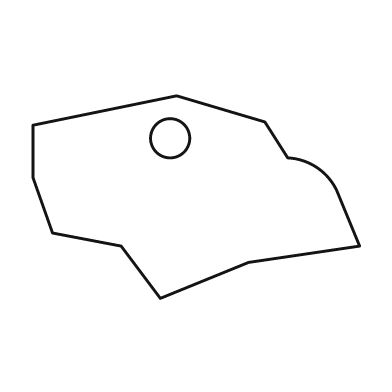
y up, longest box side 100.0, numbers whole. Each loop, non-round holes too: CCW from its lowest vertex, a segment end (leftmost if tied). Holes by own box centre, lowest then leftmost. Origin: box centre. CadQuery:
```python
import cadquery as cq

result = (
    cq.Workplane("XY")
    .moveTo(-11.0, -31.0)
    .lineTo(16.0, -20.0)
    .lineTo(50.0, -15.0)
    .lineTo(43.0, 2.0)
    .threePointArc((37.0, 9.0), (28.0, 12.0))
    .lineTo(21.0, 23.0)
    .lineTo(-6.0, 31.0)
    .lineTo(-50.0, 22.0)
    .lineTo(-50.0, 6.0)
    .lineTo(-44.0, -11.0)
    .lineTo(-23.0, -15.0)
    .close()
    .moveTo(-8.0, 18.0)
    .circle(6.0)
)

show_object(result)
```